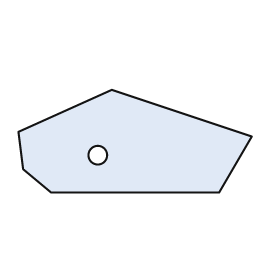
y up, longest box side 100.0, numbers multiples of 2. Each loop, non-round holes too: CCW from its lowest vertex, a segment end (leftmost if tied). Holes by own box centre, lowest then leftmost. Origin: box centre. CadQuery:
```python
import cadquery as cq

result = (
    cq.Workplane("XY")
    .moveTo(-36.0, -22.0)
    .lineTo(36.0, -22.0)
    .lineTo(50.0, 2.0)
    .lineTo(-10.0, 22.0)
    .lineTo(-50.0, 4.0)
    .lineTo(-48.0, -12.0)
    .close()
    .moveTo(-16.0, -6.0)
    .circle(4.0)
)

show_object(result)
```